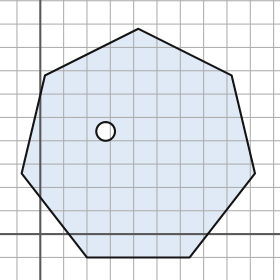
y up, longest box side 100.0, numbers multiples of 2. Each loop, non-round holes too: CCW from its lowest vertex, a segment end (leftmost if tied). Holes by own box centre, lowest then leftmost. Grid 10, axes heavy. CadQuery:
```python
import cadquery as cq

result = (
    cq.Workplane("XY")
    .moveTo(20.0, -10.0)
    .lineTo(64.0, -10.0)
    .lineTo(92.0, 26.0)
    .lineTo(82.0, 68.0)
    .lineTo(42.0, 88.0)
    .lineTo(2.0, 68.0)
    .lineTo(-8.0, 26.0)
    .close()
    .moveTo(28.0, 44.0)
    .circle(4.0)
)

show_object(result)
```